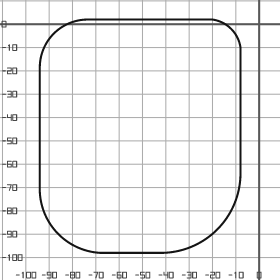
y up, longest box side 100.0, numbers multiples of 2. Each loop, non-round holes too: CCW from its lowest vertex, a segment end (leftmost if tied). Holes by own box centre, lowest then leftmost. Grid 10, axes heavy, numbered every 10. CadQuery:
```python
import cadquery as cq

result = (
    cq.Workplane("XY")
    .moveTo(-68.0, -98.0)
    .lineTo(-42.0, -98.0)
    .threePointArc((-18.0, -88.0), (-8.0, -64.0))
    .lineTo(-8.0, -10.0)
    .threePointArc((-12.0, -2.0), (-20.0, 2.0))
    .lineTo(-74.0, 2.0)
    .threePointArc((-88.0, -4.0), (-94.0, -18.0))
    .lineTo(-94.0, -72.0)
    .threePointArc((-86.0, -90.0), (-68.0, -98.0))
    .close()
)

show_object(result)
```